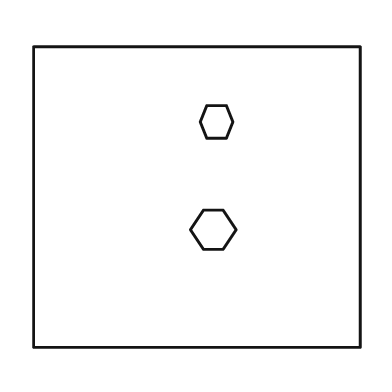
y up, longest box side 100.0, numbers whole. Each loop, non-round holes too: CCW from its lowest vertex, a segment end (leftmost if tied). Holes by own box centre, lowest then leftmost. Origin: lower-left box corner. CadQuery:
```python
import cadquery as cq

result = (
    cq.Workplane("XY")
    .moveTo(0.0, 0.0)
    .lineTo(100.0, 0.0)
    .lineTo(100.0, 92.0)
    .lineTo(0.0, 92.0)
    .close()
    .moveTo(52.0, 30.0)
    .lineTo(58.0, 30.0)
    .lineTo(62.0, 36.0)
    .lineTo(58.0, 42.0)
    .lineTo(52.0, 42.0)
    .lineTo(48.0, 36.0)
    .close()
    .moveTo(53.0, 64.0)
    .lineTo(59.0, 64.0)
    .lineTo(61.0, 69.0)
    .lineTo(59.0, 74.0)
    .lineTo(53.0, 74.0)
    .lineTo(51.0, 69.0)
    .close()
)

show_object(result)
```